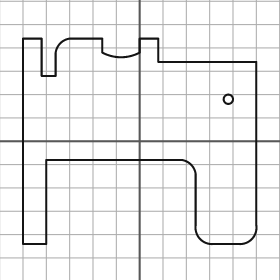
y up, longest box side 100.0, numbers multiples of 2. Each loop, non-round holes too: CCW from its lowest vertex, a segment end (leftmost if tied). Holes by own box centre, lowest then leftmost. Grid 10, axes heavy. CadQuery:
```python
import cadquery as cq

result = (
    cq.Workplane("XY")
    .moveTo(-50.0, -44.0)
    .lineTo(-40.0, -44.0)
    .lineTo(-40.0, -8.0)
    .lineTo(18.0, -8.0)
    .threePointArc((22.0, -10.0), (24.0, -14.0))
    .lineTo(24.0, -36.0)
    .threePointArc((26.0, -42.0), (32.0, -44.0))
    .lineTo(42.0, -44.0)
    .threePointArc((48.0, -42.0), (50.0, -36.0))
    .lineTo(50.0, 34.0)
    .lineTo(8.0, 34.0)
    .lineTo(8.0, 44.0)
    .lineTo(0.0, 44.0)
    .lineTo(0.0, 38.0)
    .threePointArc((-8.0, 36.0), (-16.0, 38.0))
    .lineTo(-16.0, 44.0)
    .lineTo(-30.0, 44.0)
    .threePointArc((-34.0, 42.0), (-36.0, 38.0))
    .lineTo(-36.0, 28.0)
    .lineTo(-42.0, 28.0)
    .lineTo(-42.0, 44.0)
    .lineTo(-50.0, 44.0)
    .close()
    .moveTo(38.0, 18.0)
    .circle(2.0)
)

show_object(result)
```